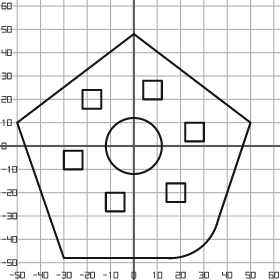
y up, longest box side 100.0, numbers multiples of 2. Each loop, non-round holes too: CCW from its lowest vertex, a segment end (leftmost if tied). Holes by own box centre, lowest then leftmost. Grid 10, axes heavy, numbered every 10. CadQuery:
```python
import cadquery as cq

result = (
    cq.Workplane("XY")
    .moveTo(-30.0, -48.0)
    .lineTo(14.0, -48.0)
    .threePointArc((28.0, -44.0), (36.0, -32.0))
    .lineTo(50.0, 10.0)
    .lineTo(0.0, 48.0)
    .lineTo(-50.0, 10.0)
    .close()
    .moveTo(-12.0, -28.0)
    .lineTo(-4.0, -28.0)
    .lineTo(-4.0, -20.0)
    .lineTo(-12.0, -20.0)
    .close()
    .moveTo(14.0, -24.0)
    .lineTo(22.0, -24.0)
    .lineTo(22.0, -16.0)
    .lineTo(14.0, -16.0)
    .close()
    .moveTo(-30.0, -10.0)
    .lineTo(-22.0, -10.0)
    .lineTo(-22.0, -2.0)
    .lineTo(-30.0, -2.0)
    .close()
    .moveTo(0.0, 0.0)
    .circle(12.0)
    .moveTo(22.0, 2.0)
    .lineTo(30.0, 2.0)
    .lineTo(30.0, 10.0)
    .lineTo(22.0, 10.0)
    .close()
    .moveTo(-22.0, 16.0)
    .lineTo(-14.0, 16.0)
    .lineTo(-14.0, 24.0)
    .lineTo(-22.0, 24.0)
    .close()
    .moveTo(4.0, 20.0)
    .lineTo(12.0, 20.0)
    .lineTo(12.0, 28.0)
    .lineTo(4.0, 28.0)
    .close()
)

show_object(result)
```